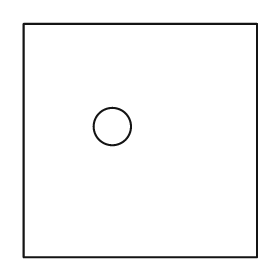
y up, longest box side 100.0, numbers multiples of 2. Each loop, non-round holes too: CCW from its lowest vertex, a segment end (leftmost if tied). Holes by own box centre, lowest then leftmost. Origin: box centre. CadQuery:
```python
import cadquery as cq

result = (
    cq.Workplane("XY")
    .moveTo(-50.0, -50.0)
    .lineTo(50.0, -50.0)
    .lineTo(50.0, 50.0)
    .lineTo(-50.0, 50.0)
    .close()
    .moveTo(-12.0, 6.0)
    .circle(8.0)
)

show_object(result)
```